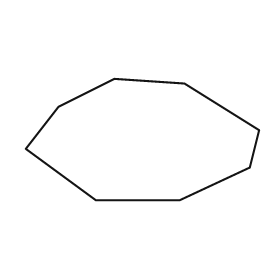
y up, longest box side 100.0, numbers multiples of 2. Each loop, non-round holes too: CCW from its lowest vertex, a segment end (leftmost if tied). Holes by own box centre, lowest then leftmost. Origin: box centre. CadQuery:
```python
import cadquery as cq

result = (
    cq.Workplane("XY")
    .moveTo(-20.0, -26.0)
    .lineTo(16.0, -26.0)
    .lineTo(46.0, -12.0)
    .lineTo(50.0, 4.0)
    .lineTo(18.0, 24.0)
    .lineTo(-12.0, 26.0)
    .lineTo(-36.0, 14.0)
    .lineTo(-50.0, -4.0)
    .close()
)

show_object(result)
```